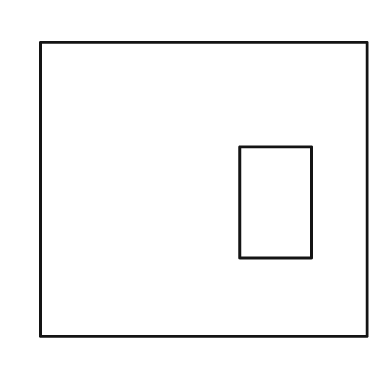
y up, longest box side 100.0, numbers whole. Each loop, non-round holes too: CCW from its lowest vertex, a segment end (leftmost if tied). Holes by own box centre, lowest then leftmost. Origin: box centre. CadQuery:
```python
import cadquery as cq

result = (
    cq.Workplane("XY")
    .moveTo(-50.0, -45.0)
    .lineTo(50.0, -45.0)
    .lineTo(50.0, 45.0)
    .lineTo(-50.0, 45.0)
    .close()
    .moveTo(11.0, -21.0)
    .lineTo(33.0, -21.0)
    .lineTo(33.0, 13.0)
    .lineTo(11.0, 13.0)
    .close()
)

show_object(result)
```